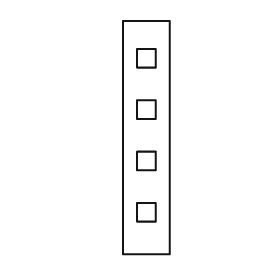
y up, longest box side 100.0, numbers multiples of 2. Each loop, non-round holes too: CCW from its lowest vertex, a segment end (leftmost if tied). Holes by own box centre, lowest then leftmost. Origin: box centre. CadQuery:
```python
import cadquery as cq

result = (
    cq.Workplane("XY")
    .moveTo(-10.0, -50.0)
    .lineTo(10.0, -50.0)
    .lineTo(10.0, 50.0)
    .lineTo(-10.0, 50.0)
    .close()
    .moveTo(-4.0, -36.0)
    .lineTo(4.0, -36.0)
    .lineTo(4.0, -28.0)
    .lineTo(-4.0, -28.0)
    .close()
    .moveTo(-4.0, -14.0)
    .lineTo(4.0, -14.0)
    .lineTo(4.0, -6.0)
    .lineTo(-4.0, -6.0)
    .close()
    .moveTo(-4.0, 8.0)
    .lineTo(4.0, 8.0)
    .lineTo(4.0, 16.0)
    .lineTo(-4.0, 16.0)
    .close()
    .moveTo(-4.0, 30.0)
    .lineTo(4.0, 30.0)
    .lineTo(4.0, 38.0)
    .lineTo(-4.0, 38.0)
    .close()
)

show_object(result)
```